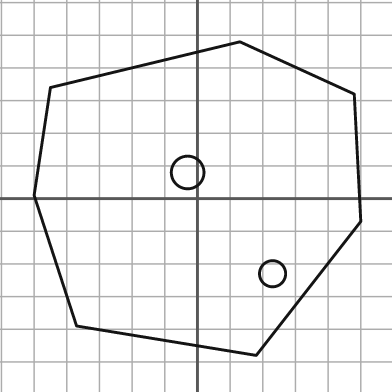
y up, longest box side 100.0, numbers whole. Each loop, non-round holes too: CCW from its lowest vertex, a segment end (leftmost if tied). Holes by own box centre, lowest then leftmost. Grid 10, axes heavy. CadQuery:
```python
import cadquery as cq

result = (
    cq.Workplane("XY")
    .moveTo(18.0, -48.0)
    .lineTo(50.0, -7.0)
    .lineTo(48.0, 32.0)
    .lineTo(13.0, 48.0)
    .lineTo(-45.0, 34.0)
    .lineTo(-50.0, 1.0)
    .lineTo(-37.0, -39.0)
    .close()
    .moveTo(23.0, -23.0)
    .circle(4.0)
    .moveTo(-3.0, 8.0)
    .circle(5.0)
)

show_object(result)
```